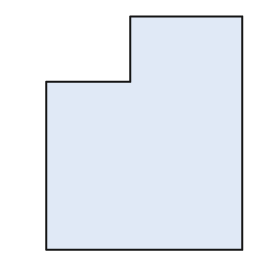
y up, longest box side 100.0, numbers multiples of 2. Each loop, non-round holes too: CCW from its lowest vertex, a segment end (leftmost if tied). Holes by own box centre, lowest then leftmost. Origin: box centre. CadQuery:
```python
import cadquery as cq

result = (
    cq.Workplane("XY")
    .moveTo(-42.0, -50.0)
    .lineTo(42.0, -50.0)
    .lineTo(42.0, 50.0)
    .lineTo(-6.0, 50.0)
    .lineTo(-6.0, 22.0)
    .lineTo(-42.0, 22.0)
    .close()
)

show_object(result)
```